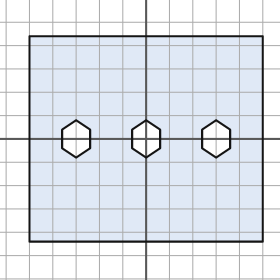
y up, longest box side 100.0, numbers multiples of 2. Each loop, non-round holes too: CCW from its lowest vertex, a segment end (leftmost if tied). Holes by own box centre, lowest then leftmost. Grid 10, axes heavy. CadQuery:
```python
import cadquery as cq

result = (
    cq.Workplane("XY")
    .moveTo(-50.0, -44.0)
    .lineTo(50.0, -44.0)
    .lineTo(50.0, 44.0)
    .lineTo(-50.0, 44.0)
    .close()
    .moveTo(-30.0, -8.0)
    .lineTo(-24.0, -4.0)
    .lineTo(-24.0, 4.0)
    .lineTo(-30.0, 8.0)
    .lineTo(-36.0, 4.0)
    .lineTo(-36.0, -4.0)
    .close()
    .moveTo(0.0, -8.0)
    .lineTo(6.0, -4.0)
    .lineTo(6.0, 4.0)
    .lineTo(0.0, 8.0)
    .lineTo(-6.0, 4.0)
    .lineTo(-6.0, -4.0)
    .close()
    .moveTo(30.0, -8.0)
    .lineTo(36.0, -4.0)
    .lineTo(36.0, 4.0)
    .lineTo(30.0, 8.0)
    .lineTo(24.0, 4.0)
    .lineTo(24.0, -4.0)
    .close()
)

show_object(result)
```